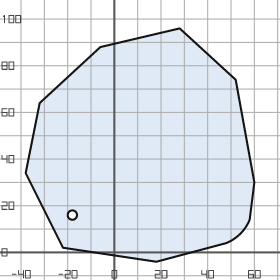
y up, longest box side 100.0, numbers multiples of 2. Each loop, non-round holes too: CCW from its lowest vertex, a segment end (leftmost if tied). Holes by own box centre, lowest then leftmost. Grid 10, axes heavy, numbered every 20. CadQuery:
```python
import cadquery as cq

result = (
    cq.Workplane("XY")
    .moveTo(18.0, -4.0)
    .lineTo(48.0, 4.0)
    .threePointArc((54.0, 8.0), (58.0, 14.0))
    .lineTo(60.0, 30.0)
    .lineTo(52.0, 74.0)
    .lineTo(28.0, 96.0)
    .lineTo(-6.0, 88.0)
    .lineTo(-32.0, 64.0)
    .lineTo(-38.0, 34.0)
    .lineTo(-22.0, 2.0)
    .close()
    .moveTo(-18.0, 16.0)
    .circle(2.0)
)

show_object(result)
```